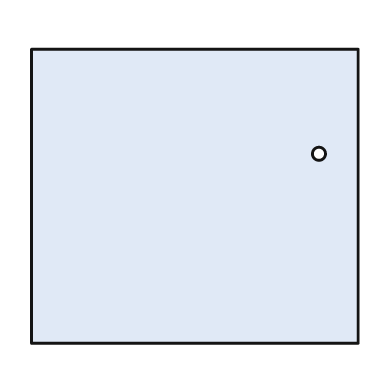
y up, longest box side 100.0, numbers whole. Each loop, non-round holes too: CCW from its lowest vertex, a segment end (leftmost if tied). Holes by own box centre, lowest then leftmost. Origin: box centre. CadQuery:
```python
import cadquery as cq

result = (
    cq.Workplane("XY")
    .moveTo(-50.0, -45.0)
    .lineTo(50.0, -45.0)
    .lineTo(50.0, 45.0)
    .lineTo(-50.0, 45.0)
    .close()
    .moveTo(38.0, 13.0)
    .circle(2.0)
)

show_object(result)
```